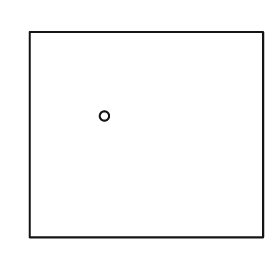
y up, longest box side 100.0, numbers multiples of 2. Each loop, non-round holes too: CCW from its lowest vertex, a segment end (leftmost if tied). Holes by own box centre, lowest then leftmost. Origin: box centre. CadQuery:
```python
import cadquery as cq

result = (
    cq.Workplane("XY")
    .moveTo(-50.0, -44.0)
    .lineTo(50.0, -44.0)
    .lineTo(50.0, 44.0)
    .lineTo(-50.0, 44.0)
    .close()
    .moveTo(-18.0, 8.0)
    .circle(2.0)
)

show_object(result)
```